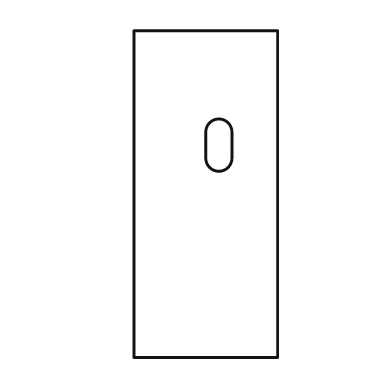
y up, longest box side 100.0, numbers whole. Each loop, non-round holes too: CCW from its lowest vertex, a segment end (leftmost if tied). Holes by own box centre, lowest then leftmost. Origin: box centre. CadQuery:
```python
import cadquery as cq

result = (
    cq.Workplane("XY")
    .moveTo(-22.0, -50.0)
    .lineTo(22.0, -50.0)
    .lineTo(22.0, 50.0)
    .lineTo(-22.0, 50.0)
    .close()
    .moveTo(0.0, 11.0)
    .threePointArc((4.0, 7.0), (8.0, 11.0))
    .lineTo(8.0, 19.0)
    .threePointArc((4.0, 23.0), (0.0, 19.0))
    .close()
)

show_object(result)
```